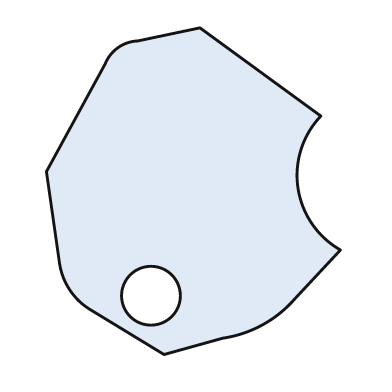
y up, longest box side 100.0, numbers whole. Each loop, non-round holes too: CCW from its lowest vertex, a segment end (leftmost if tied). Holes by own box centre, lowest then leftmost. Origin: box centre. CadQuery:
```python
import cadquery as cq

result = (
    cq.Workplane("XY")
    .moveTo(-9.0, -50.0)
    .lineTo(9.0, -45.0)
    .threePointArc((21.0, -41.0), (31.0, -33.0))
    .lineTo(45.0, -18.0)
    .threePointArc((32.0, 1.0), (39.0, 23.0))
    .lineTo(2.0, 50.0)
    .lineTo(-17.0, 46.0)
    .threePointArc((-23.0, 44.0), (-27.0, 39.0))
    .lineTo(-45.0, 6.0)
    .lineTo(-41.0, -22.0)
    .threePointArc((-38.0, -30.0), (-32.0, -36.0))
    .close()
    .moveTo(-13.0, -32.0)
    .circle(9.0)
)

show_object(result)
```